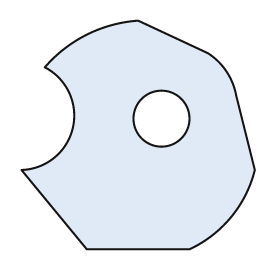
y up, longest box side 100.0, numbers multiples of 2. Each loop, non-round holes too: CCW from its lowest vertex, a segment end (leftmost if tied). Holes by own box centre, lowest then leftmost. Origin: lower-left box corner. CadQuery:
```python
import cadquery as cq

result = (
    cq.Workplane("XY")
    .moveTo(28.0, 0.0)
    .lineTo(72.0, 0.0)
    .threePointArc((90.0, 14.0), (100.0, 34.0))
    .lineTo(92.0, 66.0)
    .threePointArc((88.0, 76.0), (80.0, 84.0))
    .lineTo(50.0, 98.0)
    .threePointArc((28.0, 92.0), (10.0, 78.0))
    .threePointArc((22.0, 52.0), (0.0, 34.0))
    .close()
    .moveTo(60.0, 56.0)
    .circle(12.0)
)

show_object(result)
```